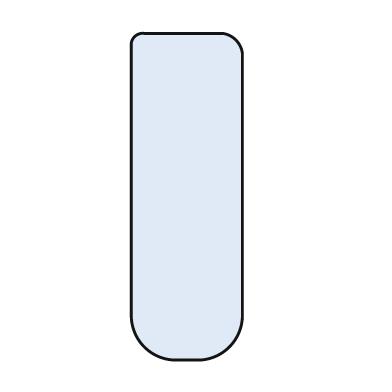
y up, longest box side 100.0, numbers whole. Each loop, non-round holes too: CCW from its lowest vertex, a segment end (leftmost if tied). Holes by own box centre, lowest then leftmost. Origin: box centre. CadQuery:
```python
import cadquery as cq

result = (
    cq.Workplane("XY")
    .moveTo(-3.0, -50.0)
    .lineTo(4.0, -50.0)
    .threePointArc((13.0, -46.0), (17.0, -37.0))
    .lineTo(17.0, 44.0)
    .threePointArc((15.0, 48.0), (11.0, 50.0))
    .lineTo(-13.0, 50.0)
    .threePointArc((-16.0, 49.0), (-17.0, 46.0))
    .lineTo(-17.0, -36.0)
    .threePointArc((-13.0, -46.0), (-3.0, -50.0))
    .close()
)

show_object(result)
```